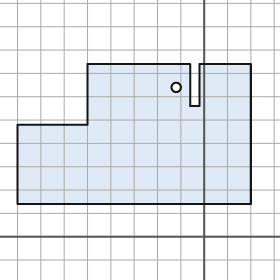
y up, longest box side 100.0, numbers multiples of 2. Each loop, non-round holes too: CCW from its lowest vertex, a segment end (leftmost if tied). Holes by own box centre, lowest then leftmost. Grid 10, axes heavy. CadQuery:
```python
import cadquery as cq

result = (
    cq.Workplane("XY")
    .moveTo(-80.0, 14.0)
    .lineTo(20.0, 14.0)
    .lineTo(20.0, 74.0)
    .lineTo(-2.0, 74.0)
    .lineTo(-2.0, 56.0)
    .lineTo(-6.0, 56.0)
    .lineTo(-6.0, 74.0)
    .lineTo(-50.0, 74.0)
    .lineTo(-50.0, 48.0)
    .lineTo(-80.0, 48.0)
    .close()
    .moveTo(-12.0, 64.0)
    .circle(2.0)
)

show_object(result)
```